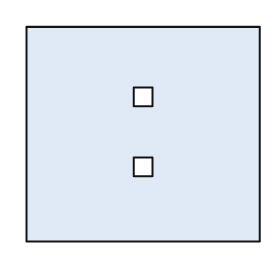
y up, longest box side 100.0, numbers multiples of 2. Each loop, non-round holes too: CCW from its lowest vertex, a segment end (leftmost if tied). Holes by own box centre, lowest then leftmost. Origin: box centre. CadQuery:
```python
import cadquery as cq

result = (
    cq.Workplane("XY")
    .moveTo(-50.0, -46.0)
    .lineTo(50.0, -46.0)
    .lineTo(50.0, 46.0)
    .lineTo(-50.0, 46.0)
    .close()
    .moveTo(-4.0, -18.0)
    .lineTo(4.0, -18.0)
    .lineTo(4.0, -10.0)
    .lineTo(-4.0, -10.0)
    .close()
    .moveTo(-4.0, 12.0)
    .lineTo(4.0, 12.0)
    .lineTo(4.0, 20.0)
    .lineTo(-4.0, 20.0)
    .close()
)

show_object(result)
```